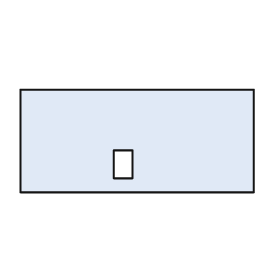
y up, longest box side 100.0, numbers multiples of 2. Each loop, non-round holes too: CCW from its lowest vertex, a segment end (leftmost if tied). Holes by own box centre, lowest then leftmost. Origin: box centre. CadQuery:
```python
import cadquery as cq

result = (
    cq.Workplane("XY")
    .moveTo(-50.0, -22.0)
    .lineTo(50.0, -22.0)
    .lineTo(50.0, 22.0)
    .lineTo(-50.0, 22.0)
    .close()
    .moveTo(-10.0, -16.0)
    .lineTo(-2.0, -16.0)
    .lineTo(-2.0, -4.0)
    .lineTo(-10.0, -4.0)
    .close()
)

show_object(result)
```